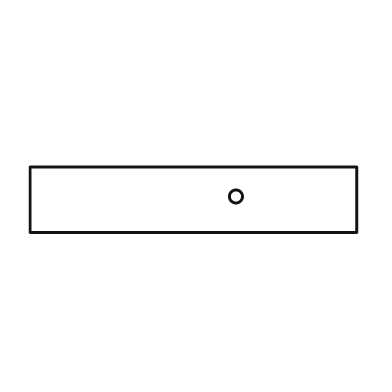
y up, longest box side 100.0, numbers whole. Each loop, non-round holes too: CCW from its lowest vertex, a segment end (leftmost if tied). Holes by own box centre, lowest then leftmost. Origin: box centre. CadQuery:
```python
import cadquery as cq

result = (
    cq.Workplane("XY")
    .moveTo(-50.0, -10.0)
    .lineTo(50.0, -10.0)
    .lineTo(50.0, 10.0)
    .lineTo(-50.0, 10.0)
    .close()
    .moveTo(13.0, 1.0)
    .circle(2.0)
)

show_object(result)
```